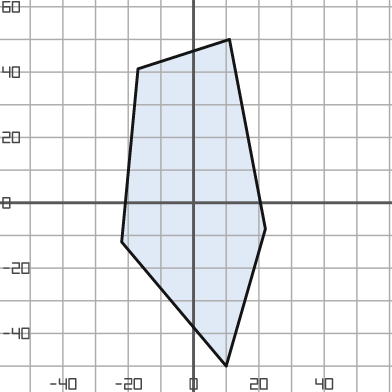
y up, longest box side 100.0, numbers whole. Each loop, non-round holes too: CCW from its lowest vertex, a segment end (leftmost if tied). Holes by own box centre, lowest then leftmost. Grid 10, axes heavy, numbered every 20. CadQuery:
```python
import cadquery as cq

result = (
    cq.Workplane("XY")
    .moveTo(10.0, -50.0)
    .lineTo(22.0, -8.0)
    .lineTo(11.0, 50.0)
    .lineTo(-17.0, 41.0)
    .lineTo(-22.0, -12.0)
    .close()
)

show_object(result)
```